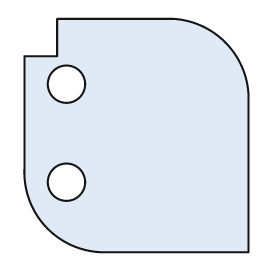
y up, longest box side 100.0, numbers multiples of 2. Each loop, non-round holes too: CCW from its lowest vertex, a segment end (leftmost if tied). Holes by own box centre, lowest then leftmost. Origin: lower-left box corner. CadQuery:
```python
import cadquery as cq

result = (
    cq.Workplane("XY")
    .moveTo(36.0, 0.0)
    .lineTo(96.0, 0.0)
    .lineTo(96.0, 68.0)
    .threePointArc((86.0, 90.0), (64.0, 100.0))
    .lineTo(14.0, 100.0)
    .lineTo(14.0, 84.0)
    .lineTo(0.0, 84.0)
    .lineTo(0.0, 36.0)
    .threePointArc((10.0, 10.0), (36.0, 0.0))
    .close()
    .moveTo(18.0, 30.0)
    .circle(8.0)
    .moveTo(18.0, 72.0)
    .circle(8.0)
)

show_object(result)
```